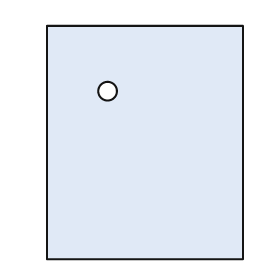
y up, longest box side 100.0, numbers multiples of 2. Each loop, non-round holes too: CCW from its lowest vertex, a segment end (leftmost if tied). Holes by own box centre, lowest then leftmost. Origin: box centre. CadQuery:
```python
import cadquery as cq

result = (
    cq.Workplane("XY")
    .moveTo(-42.0, -50.0)
    .lineTo(42.0, -50.0)
    .lineTo(42.0, 50.0)
    .lineTo(-42.0, 50.0)
    .close()
    .moveTo(-16.0, 22.0)
    .circle(4.0)
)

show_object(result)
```